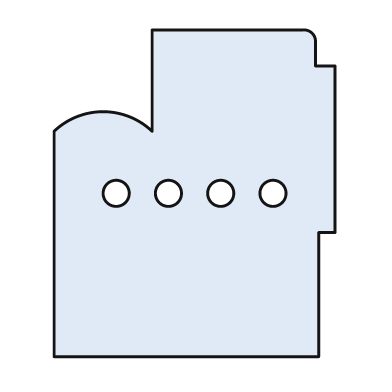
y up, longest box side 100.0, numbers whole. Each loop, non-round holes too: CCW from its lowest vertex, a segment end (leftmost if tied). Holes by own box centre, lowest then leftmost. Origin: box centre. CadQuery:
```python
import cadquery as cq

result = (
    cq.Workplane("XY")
    .moveTo(-43.0, -50.0)
    .lineTo(38.0, -50.0)
    .lineTo(38.0, -12.0)
    .lineTo(43.0, -12.0)
    .lineTo(43.0, 39.0)
    .lineTo(37.0, 39.0)
    .lineTo(37.0, 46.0)
    .threePointArc((36.0, 49.0), (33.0, 50.0))
    .lineTo(-13.0, 50.0)
    .lineTo(-13.0, 19.0)
    .threePointArc((-28.0, 25.0), (-43.0, 19.0))
    .close()
    .moveTo(-24.0, 0.0)
    .circle(4.0)
    .moveTo(-8.0, 0.0)
    .circle(4.0)
    .moveTo(8.0, 0.0)
    .circle(4.0)
    .moveTo(24.0, 0.0)
    .circle(4.0)
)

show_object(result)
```